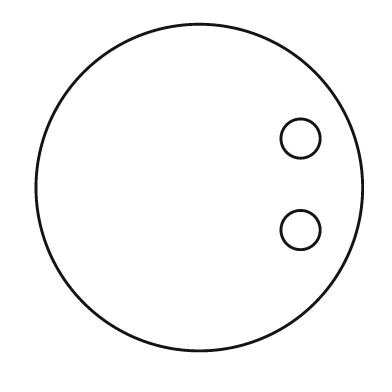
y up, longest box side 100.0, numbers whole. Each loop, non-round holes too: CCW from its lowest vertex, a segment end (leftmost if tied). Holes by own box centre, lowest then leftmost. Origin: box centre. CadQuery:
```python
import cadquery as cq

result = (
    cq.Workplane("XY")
    .moveTo(0.0, 0.0)
    .circle(50.0)
    .moveTo(31.0, -13.0)
    .circle(6.0)
    .moveTo(31.0, 15.0)
    .circle(6.0)
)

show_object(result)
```